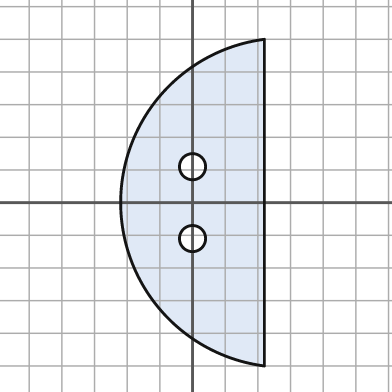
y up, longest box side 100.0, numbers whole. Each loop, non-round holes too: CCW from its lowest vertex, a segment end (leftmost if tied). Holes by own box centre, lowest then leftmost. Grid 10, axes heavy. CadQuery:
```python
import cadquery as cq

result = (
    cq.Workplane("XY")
    .moveTo(22.0, -50.0)
    .lineTo(22.0, 50.0)
    .threePointArc((-22.0, 0.0), (22.0, -50.0))
    .close()
    .moveTo(0.0, -11.0)
    .circle(4.0)
    .moveTo(0.0, 11.0)
    .circle(4.0)
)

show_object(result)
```